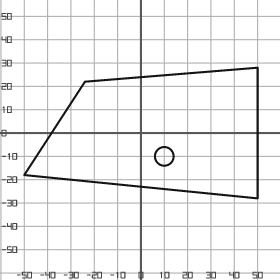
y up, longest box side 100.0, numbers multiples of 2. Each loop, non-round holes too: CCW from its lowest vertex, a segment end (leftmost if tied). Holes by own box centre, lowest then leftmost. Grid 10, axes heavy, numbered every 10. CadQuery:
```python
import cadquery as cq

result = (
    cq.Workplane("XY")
    .moveTo(50.0, -28.0)
    .lineTo(50.0, 28.0)
    .lineTo(-24.0, 22.0)
    .lineTo(-50.0, -18.0)
    .close()
    .moveTo(10.0, -10.0)
    .circle(4.0)
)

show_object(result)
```